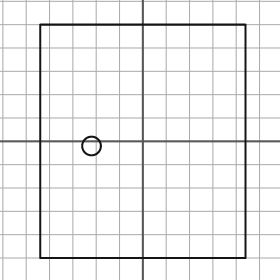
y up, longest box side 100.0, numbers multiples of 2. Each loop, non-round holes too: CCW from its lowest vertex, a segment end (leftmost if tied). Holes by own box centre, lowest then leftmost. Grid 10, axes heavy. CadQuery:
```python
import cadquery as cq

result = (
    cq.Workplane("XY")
    .moveTo(-44.0, -50.0)
    .lineTo(44.0, -50.0)
    .lineTo(44.0, 50.0)
    .lineTo(-44.0, 50.0)
    .close()
    .moveTo(-22.0, -2.0)
    .circle(4.0)
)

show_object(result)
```